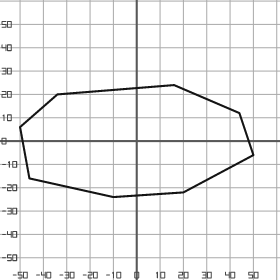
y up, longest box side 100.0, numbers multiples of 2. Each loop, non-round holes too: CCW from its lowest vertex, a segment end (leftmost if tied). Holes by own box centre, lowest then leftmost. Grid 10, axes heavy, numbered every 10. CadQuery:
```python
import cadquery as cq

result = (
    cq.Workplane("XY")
    .moveTo(-10.0, -24.0)
    .lineTo(20.0, -22.0)
    .lineTo(50.0, -6.0)
    .lineTo(44.0, 12.0)
    .lineTo(16.0, 24.0)
    .lineTo(-34.0, 20.0)
    .lineTo(-50.0, 6.0)
    .lineTo(-46.0, -16.0)
    .close()
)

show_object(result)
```